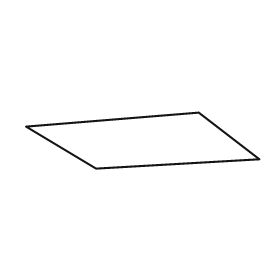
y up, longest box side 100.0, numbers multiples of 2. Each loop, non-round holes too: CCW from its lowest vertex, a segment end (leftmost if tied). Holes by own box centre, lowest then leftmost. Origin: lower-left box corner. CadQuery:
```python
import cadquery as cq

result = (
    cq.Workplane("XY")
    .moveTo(30.0, 0.0)
    .lineTo(100.0, 4.0)
    .lineTo(74.0, 24.0)
    .lineTo(0.0, 18.0)
    .close()
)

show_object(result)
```